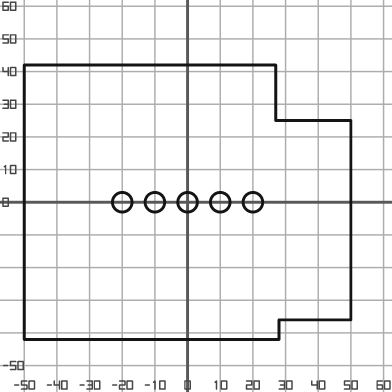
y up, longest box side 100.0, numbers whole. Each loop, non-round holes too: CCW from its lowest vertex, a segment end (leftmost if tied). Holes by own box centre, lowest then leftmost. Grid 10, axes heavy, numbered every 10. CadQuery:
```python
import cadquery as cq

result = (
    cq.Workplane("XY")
    .moveTo(-50.0, -42.0)
    .lineTo(28.0, -42.0)
    .lineTo(28.0, -36.0)
    .lineTo(50.0, -36.0)
    .lineTo(50.0, 25.0)
    .lineTo(27.0, 25.0)
    .lineTo(27.0, 42.0)
    .lineTo(-50.0, 42.0)
    .close()
    .moveTo(-20.0, 0.0)
    .circle(3.0)
    .moveTo(-10.0, 0.0)
    .circle(3.0)
    .moveTo(0.0, 0.0)
    .circle(3.0)
    .moveTo(10.0, 0.0)
    .circle(3.0)
    .moveTo(20.0, 0.0)
    .circle(3.0)
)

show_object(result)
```